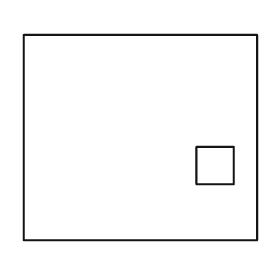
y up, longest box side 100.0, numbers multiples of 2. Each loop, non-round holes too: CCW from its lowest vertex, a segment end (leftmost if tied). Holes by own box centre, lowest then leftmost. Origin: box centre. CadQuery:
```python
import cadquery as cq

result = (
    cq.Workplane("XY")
    .moveTo(-50.0, -44.0)
    .lineTo(50.0, -44.0)
    .lineTo(50.0, 44.0)
    .lineTo(-50.0, 44.0)
    .close()
    .moveTo(24.0, -20.0)
    .lineTo(40.0, -20.0)
    .lineTo(40.0, -4.0)
    .lineTo(24.0, -4.0)
    .close()
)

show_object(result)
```